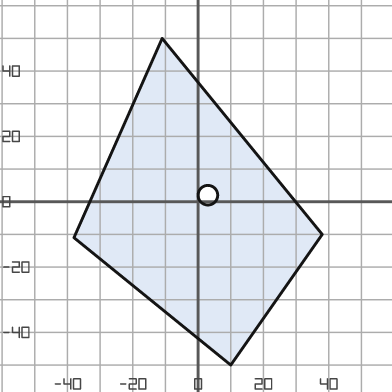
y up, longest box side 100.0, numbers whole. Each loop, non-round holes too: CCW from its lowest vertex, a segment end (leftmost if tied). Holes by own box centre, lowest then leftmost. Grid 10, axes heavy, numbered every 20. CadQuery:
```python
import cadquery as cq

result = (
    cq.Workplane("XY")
    .moveTo(10.0, -50.0)
    .lineTo(38.0, -10.0)
    .lineTo(-11.0, 50.0)
    .lineTo(-38.0, -11.0)
    .close()
    .moveTo(3.0, 2.0)
    .circle(3.0)
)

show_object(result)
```